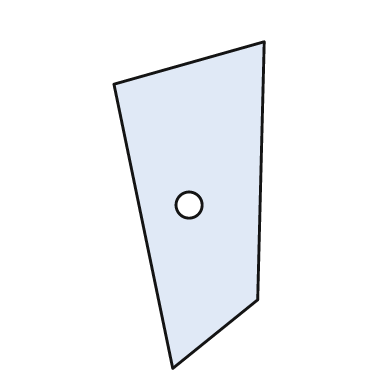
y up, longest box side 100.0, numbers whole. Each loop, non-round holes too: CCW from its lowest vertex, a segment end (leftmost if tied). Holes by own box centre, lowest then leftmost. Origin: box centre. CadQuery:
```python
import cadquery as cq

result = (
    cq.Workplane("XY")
    .moveTo(-5.0, -50.0)
    .lineTo(21.0, -29.0)
    .lineTo(23.0, 50.0)
    .lineTo(-23.0, 37.0)
    .close()
    .moveTo(0.0, 0.0)
    .circle(4.0)
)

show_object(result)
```